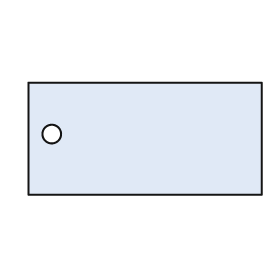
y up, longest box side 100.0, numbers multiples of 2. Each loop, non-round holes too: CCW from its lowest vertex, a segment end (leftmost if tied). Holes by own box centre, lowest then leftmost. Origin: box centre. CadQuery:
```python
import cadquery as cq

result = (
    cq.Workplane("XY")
    .moveTo(-50.0, -24.0)
    .lineTo(50.0, -24.0)
    .lineTo(50.0, 24.0)
    .lineTo(-50.0, 24.0)
    .close()
    .moveTo(-40.0, 2.0)
    .circle(4.0)
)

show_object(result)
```